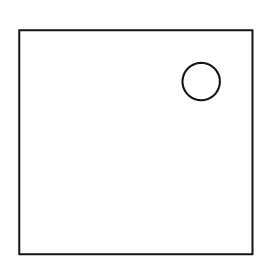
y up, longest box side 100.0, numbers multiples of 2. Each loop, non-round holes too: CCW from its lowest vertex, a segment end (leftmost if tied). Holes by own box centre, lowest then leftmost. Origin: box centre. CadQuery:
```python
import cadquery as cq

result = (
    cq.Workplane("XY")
    .moveTo(-50.0, -48.0)
    .lineTo(50.0, -48.0)
    .lineTo(50.0, 48.0)
    .lineTo(-50.0, 48.0)
    .close()
    .moveTo(28.0, 26.0)
    .circle(8.0)
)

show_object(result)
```